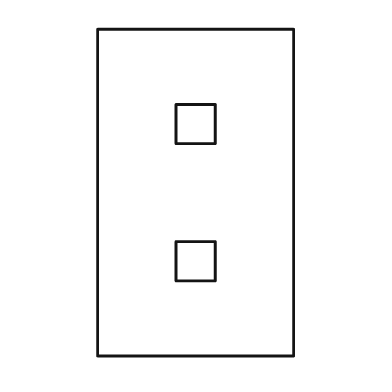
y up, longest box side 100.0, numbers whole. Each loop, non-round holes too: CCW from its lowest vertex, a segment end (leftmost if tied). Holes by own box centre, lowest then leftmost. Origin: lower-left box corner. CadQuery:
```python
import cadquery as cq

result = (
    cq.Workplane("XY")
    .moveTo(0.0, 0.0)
    .lineTo(60.0, 0.0)
    .lineTo(60.0, 100.0)
    .lineTo(0.0, 100.0)
    .close()
    .moveTo(24.0, 23.0)
    .lineTo(36.0, 23.0)
    .lineTo(36.0, 35.0)
    .lineTo(24.0, 35.0)
    .close()
    .moveTo(24.0, 65.0)
    .lineTo(36.0, 65.0)
    .lineTo(36.0, 77.0)
    .lineTo(24.0, 77.0)
    .close()
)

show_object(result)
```